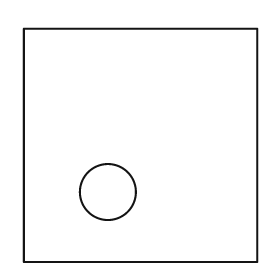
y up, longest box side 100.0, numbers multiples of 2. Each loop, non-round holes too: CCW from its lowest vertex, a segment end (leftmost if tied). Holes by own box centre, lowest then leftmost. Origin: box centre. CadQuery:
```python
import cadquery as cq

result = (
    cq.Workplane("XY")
    .moveTo(-50.0, -50.0)
    .lineTo(50.0, -50.0)
    .lineTo(50.0, 50.0)
    .lineTo(-50.0, 50.0)
    .close()
    .moveTo(-14.0, -20.0)
    .circle(12.0)
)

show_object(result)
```